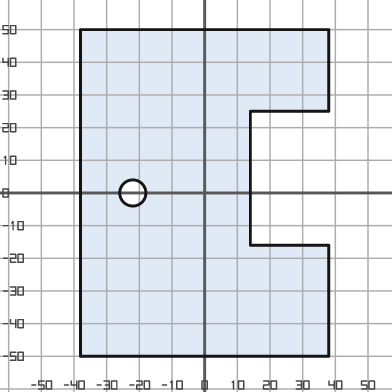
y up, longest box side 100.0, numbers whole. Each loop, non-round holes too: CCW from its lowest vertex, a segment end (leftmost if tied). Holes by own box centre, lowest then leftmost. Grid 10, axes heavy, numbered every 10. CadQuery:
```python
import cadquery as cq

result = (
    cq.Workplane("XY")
    .moveTo(-38.0, -50.0)
    .lineTo(38.0, -50.0)
    .lineTo(38.0, -16.0)
    .lineTo(14.0, -16.0)
    .lineTo(14.0, 25.0)
    .lineTo(38.0, 25.0)
    .lineTo(38.0, 50.0)
    .lineTo(-38.0, 50.0)
    .close()
    .moveTo(-22.0, 0.0)
    .circle(4.0)
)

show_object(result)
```